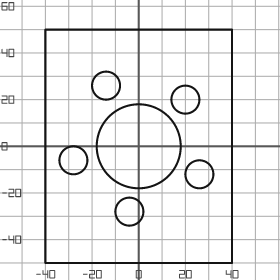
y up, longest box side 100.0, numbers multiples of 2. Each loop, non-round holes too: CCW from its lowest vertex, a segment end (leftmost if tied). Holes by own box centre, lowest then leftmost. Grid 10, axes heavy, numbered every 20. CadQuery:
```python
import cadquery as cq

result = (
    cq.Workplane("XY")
    .moveTo(-40.0, -50.0)
    .lineTo(40.0, -50.0)
    .lineTo(40.0, 50.0)
    .lineTo(-40.0, 50.0)
    .close()
    .moveTo(-4.0, -28.0)
    .circle(6.0)
    .moveTo(26.0, -12.0)
    .circle(6.0)
    .moveTo(-28.0, -6.0)
    .circle(6.0)
    .moveTo(0.0, 0.0)
    .circle(18.0)
    .moveTo(20.0, 20.0)
    .circle(6.0)
    .moveTo(-14.0, 26.0)
    .circle(6.0)
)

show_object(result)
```